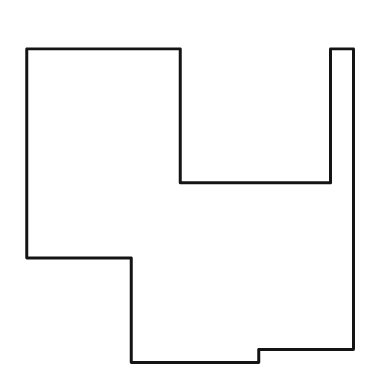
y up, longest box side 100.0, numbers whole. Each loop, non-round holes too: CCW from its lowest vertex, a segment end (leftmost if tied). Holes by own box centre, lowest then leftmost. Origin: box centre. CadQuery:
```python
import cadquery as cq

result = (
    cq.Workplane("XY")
    .moveTo(-18.0, -48.0)
    .lineTo(21.0, -48.0)
    .lineTo(21.0, -44.0)
    .lineTo(50.0, -44.0)
    .lineTo(50.0, 48.0)
    .lineTo(43.0, 48.0)
    .lineTo(43.0, 7.0)
    .lineTo(-3.0, 7.0)
    .lineTo(-3.0, 48.0)
    .lineTo(-50.0, 48.0)
    .lineTo(-50.0, -16.0)
    .lineTo(-18.0, -16.0)
    .close()
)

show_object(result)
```